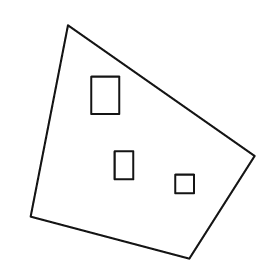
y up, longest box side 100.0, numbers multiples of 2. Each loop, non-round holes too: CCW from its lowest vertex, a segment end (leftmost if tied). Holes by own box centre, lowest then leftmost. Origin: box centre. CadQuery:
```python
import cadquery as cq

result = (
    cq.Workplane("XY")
    .moveTo(20.0, -50.0)
    .lineTo(48.0, -6.0)
    .lineTo(-32.0, 50.0)
    .lineTo(-48.0, -32.0)
    .close()
    .moveTo(14.0, -22.0)
    .lineTo(22.0, -22.0)
    .lineTo(22.0, -14.0)
    .lineTo(14.0, -14.0)
    .close()
    .moveTo(-12.0, -16.0)
    .lineTo(-4.0, -16.0)
    .lineTo(-4.0, -4.0)
    .lineTo(-12.0, -4.0)
    .close()
    .moveTo(-22.0, 12.0)
    .lineTo(-10.0, 12.0)
    .lineTo(-10.0, 28.0)
    .lineTo(-22.0, 28.0)
    .close()
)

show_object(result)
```